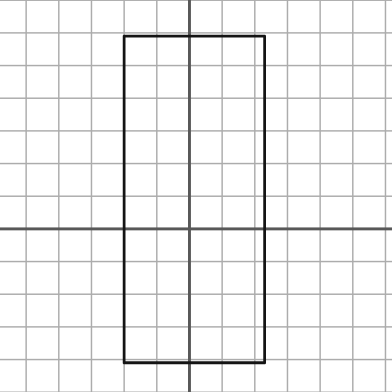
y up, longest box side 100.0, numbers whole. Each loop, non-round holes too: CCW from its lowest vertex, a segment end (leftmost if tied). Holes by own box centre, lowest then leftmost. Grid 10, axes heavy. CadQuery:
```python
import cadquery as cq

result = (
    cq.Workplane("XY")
    .moveTo(-20.0, -41.0)
    .lineTo(23.0, -41.0)
    .lineTo(23.0, 59.0)
    .lineTo(-20.0, 59.0)
    .close()
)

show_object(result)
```